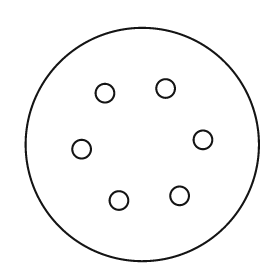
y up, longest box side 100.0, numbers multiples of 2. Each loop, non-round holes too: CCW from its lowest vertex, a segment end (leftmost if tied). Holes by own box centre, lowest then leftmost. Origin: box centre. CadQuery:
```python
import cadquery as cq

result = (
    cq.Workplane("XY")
    .moveTo(0.0, 0.0)
    .circle(50.0)
    .moveTo(-10.0, -24.0)
    .circle(4.0)
    .moveTo(16.0, -22.0)
    .circle(4.0)
    .moveTo(-26.0, -2.0)
    .circle(4.0)
    .moveTo(26.0, 2.0)
    .circle(4.0)
    .moveTo(-16.0, 22.0)
    .circle(4.0)
    .moveTo(10.0, 24.0)
    .circle(4.0)
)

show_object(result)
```